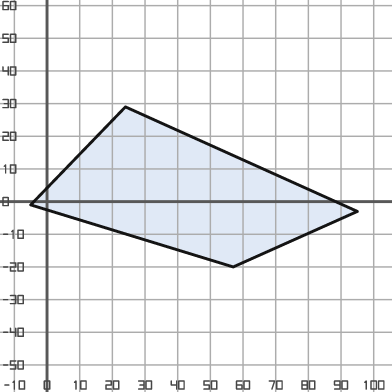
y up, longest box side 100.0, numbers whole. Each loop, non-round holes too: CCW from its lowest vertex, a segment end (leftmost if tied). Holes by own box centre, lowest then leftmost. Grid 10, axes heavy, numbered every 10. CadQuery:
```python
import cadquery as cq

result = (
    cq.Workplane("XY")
    .moveTo(57.0, -20.0)
    .lineTo(95.0, -3.0)
    .lineTo(24.0, 29.0)
    .lineTo(-5.0, -1.0)
    .close()
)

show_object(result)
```